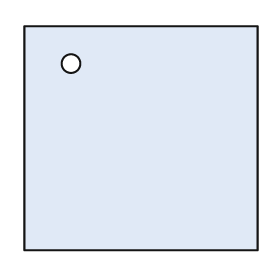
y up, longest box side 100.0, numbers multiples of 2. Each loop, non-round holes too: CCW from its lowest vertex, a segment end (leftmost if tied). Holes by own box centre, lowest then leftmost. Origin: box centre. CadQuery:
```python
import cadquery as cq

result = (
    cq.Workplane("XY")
    .moveTo(-50.0, -48.0)
    .lineTo(50.0, -48.0)
    .lineTo(50.0, 48.0)
    .lineTo(-50.0, 48.0)
    .close()
    .moveTo(-30.0, 32.0)
    .circle(4.0)
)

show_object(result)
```